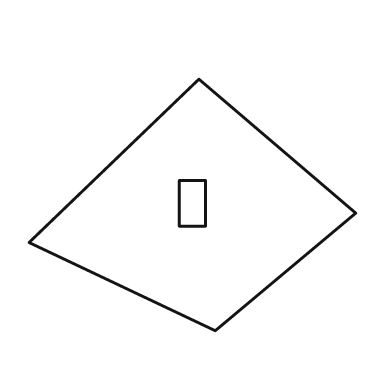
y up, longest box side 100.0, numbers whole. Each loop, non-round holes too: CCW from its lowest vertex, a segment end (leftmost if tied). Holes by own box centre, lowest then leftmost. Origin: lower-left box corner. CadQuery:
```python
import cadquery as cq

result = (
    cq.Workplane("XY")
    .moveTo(57.0, 0.0)
    .lineTo(100.0, 36.0)
    .lineTo(52.0, 77.0)
    .lineTo(0.0, 27.0)
    .close()
    .moveTo(46.0, 32.0)
    .lineTo(54.0, 32.0)
    .lineTo(54.0, 46.0)
    .lineTo(46.0, 46.0)
    .close()
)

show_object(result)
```